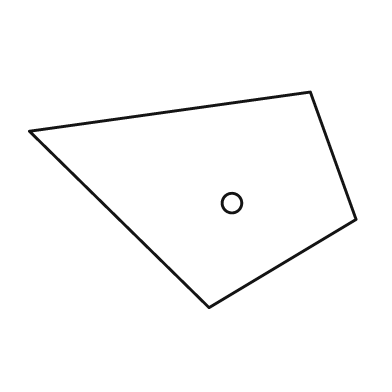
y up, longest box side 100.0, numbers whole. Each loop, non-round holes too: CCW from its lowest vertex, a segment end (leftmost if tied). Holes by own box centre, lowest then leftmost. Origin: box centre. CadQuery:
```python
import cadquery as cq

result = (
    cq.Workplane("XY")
    .moveTo(5.0, -33.0)
    .lineTo(50.0, -6.0)
    .lineTo(36.0, 33.0)
    .lineTo(-50.0, 21.0)
    .close()
    .moveTo(12.0, -1.0)
    .circle(3.0)
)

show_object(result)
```